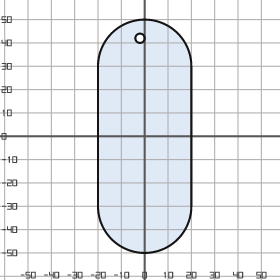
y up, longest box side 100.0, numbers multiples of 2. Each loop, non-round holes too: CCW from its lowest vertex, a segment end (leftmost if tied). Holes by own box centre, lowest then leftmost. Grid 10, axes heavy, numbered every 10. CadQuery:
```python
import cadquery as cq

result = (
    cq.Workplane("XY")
    .moveTo(-20.0, -30.0)
    .threePointArc((0.0, -50.0), (20.0, -30.0))
    .lineTo(20.0, 30.0)
    .threePointArc((0.0, 50.0), (-20.0, 30.0))
    .close()
    .moveTo(-2.0, 42.0)
    .circle(2.0)
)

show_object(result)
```